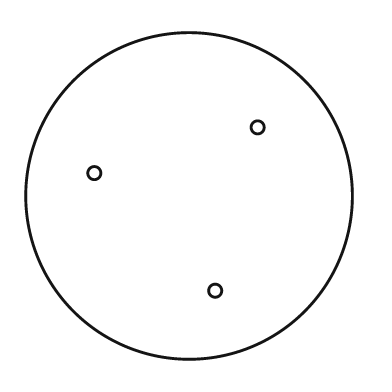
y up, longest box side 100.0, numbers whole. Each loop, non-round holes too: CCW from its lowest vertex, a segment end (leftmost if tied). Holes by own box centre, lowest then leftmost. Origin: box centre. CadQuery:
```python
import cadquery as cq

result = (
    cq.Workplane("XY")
    .moveTo(0.0, 0.0)
    .circle(50.0)
    .moveTo(8.0, -29.0)
    .circle(2.0)
    .moveTo(-29.0, 7.0)
    .circle(2.0)
    .moveTo(21.0, 21.0)
    .circle(2.0)
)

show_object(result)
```